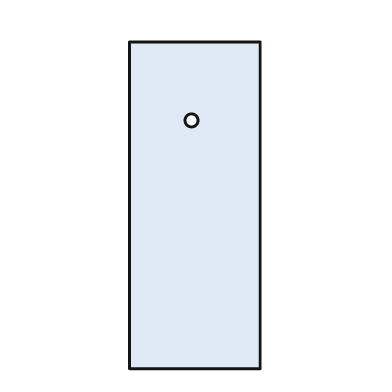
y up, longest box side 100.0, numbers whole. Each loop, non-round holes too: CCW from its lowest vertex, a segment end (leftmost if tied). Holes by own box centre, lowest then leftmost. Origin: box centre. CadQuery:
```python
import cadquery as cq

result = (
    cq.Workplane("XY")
    .moveTo(-20.0, -50.0)
    .lineTo(20.0, -50.0)
    .lineTo(20.0, 50.0)
    .lineTo(-20.0, 50.0)
    .close()
    .moveTo(-1.0, 26.0)
    .circle(2.0)
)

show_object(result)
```